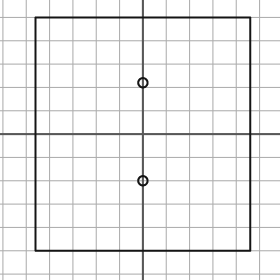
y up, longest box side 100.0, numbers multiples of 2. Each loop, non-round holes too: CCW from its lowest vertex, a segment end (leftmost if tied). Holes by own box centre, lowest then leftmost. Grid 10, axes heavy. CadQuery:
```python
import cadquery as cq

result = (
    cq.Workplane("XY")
    .moveTo(-46.0, -50.0)
    .lineTo(46.0, -50.0)
    .lineTo(46.0, 50.0)
    .lineTo(-46.0, 50.0)
    .close()
    .moveTo(0.0, -20.0)
    .circle(2.0)
    .moveTo(0.0, 22.0)
    .circle(2.0)
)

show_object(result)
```